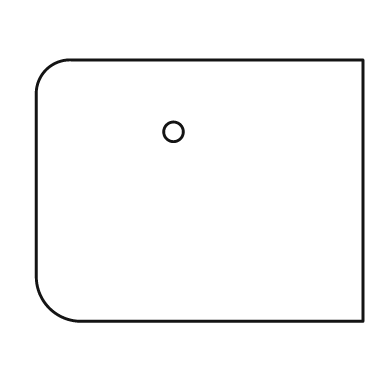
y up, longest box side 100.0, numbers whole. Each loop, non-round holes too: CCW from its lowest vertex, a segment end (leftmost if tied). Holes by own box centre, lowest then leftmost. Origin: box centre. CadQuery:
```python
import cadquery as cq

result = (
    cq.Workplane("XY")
    .moveTo(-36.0, -40.0)
    .lineTo(50.0, -40.0)
    .lineTo(50.0, 40.0)
    .lineTo(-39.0, 40.0)
    .threePointArc((-47.0, 37.0), (-50.0, 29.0))
    .lineTo(-50.0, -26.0)
    .threePointArc((-46.0, -36.0), (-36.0, -40.0))
    .close()
    .moveTo(-8.0, 18.0)
    .circle(3.0)
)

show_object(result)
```